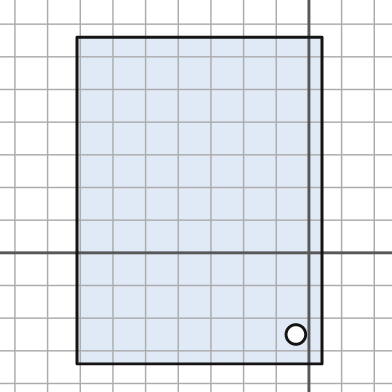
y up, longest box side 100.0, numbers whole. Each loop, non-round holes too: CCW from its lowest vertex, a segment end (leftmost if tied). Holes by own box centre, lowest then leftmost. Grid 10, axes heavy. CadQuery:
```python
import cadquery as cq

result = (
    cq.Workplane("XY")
    .moveTo(-71.0, -34.0)
    .lineTo(4.0, -34.0)
    .lineTo(4.0, 66.0)
    .lineTo(-71.0, 66.0)
    .close()
    .moveTo(-4.0, -25.0)
    .circle(3.0)
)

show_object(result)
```